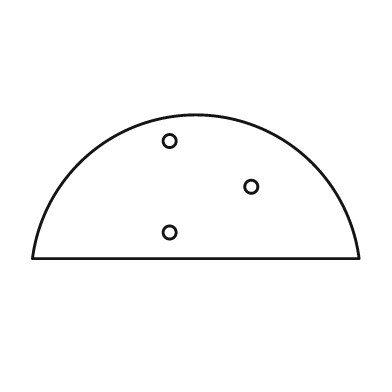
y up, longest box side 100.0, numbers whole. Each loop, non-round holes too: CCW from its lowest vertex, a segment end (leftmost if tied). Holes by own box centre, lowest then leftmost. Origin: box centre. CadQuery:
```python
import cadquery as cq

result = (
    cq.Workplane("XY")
    .moveTo(-50.0, -22.0)
    .lineTo(50.0, -22.0)
    .threePointArc((0.0, 22.0), (-50.0, -22.0))
    .close()
    .moveTo(-8.0, -14.0)
    .circle(2.0)
    .moveTo(17.0, 0.0)
    .circle(2.0)
    .moveTo(-8.0, 14.0)
    .circle(2.0)
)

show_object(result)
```